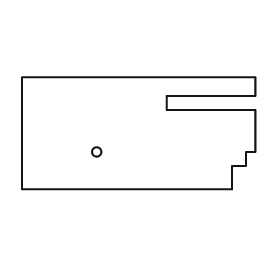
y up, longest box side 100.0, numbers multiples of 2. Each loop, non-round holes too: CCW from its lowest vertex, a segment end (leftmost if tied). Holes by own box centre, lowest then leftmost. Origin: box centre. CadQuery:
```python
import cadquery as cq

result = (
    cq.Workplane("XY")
    .moveTo(-50.0, -24.0)
    .lineTo(40.0, -24.0)
    .lineTo(40.0, -14.0)
    .lineTo(46.0, -14.0)
    .lineTo(46.0, -8.0)
    .lineTo(50.0, -8.0)
    .lineTo(50.0, 10.0)
    .lineTo(12.0, 10.0)
    .lineTo(12.0, 16.0)
    .lineTo(50.0, 16.0)
    .lineTo(50.0, 24.0)
    .lineTo(-50.0, 24.0)
    .close()
    .moveTo(-18.0, -8.0)
    .circle(2.0)
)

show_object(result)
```